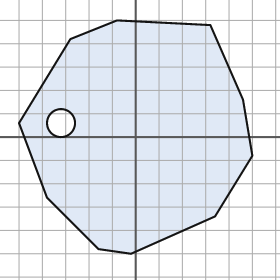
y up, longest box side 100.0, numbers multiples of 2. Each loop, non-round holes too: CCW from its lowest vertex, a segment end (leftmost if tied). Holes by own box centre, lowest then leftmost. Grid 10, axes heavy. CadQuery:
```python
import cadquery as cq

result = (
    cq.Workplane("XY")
    .moveTo(-2.0, -50.0)
    .lineTo(34.0, -34.0)
    .lineTo(50.0, -8.0)
    .lineTo(46.0, 16.0)
    .lineTo(32.0, 48.0)
    .lineTo(-8.0, 50.0)
    .lineTo(-28.0, 42.0)
    .lineTo(-50.0, 6.0)
    .lineTo(-38.0, -26.0)
    .lineTo(-16.0, -48.0)
    .close()
    .moveTo(-32.0, 6.0)
    .circle(6.0)
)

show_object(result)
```